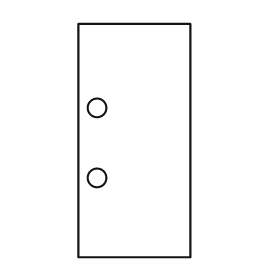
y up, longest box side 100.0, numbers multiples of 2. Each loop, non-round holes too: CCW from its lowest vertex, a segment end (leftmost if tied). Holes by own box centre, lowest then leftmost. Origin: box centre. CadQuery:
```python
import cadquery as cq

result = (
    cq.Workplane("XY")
    .moveTo(-24.0, -50.0)
    .lineTo(24.0, -50.0)
    .lineTo(24.0, 50.0)
    .lineTo(-24.0, 50.0)
    .close()
    .moveTo(-16.0, -16.0)
    .circle(4.0)
    .moveTo(-16.0, 14.0)
    .circle(4.0)
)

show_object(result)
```